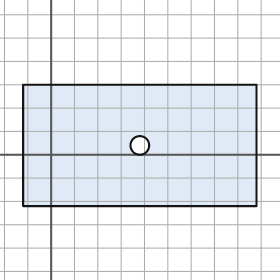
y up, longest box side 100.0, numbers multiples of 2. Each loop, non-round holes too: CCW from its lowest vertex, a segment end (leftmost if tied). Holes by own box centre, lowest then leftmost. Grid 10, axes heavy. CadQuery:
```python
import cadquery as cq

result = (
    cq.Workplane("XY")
    .moveTo(-12.0, -22.0)
    .lineTo(88.0, -22.0)
    .lineTo(88.0, 30.0)
    .lineTo(-12.0, 30.0)
    .close()
    .moveTo(38.0, 4.0)
    .circle(4.0)
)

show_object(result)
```